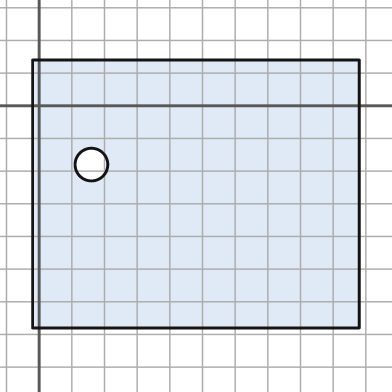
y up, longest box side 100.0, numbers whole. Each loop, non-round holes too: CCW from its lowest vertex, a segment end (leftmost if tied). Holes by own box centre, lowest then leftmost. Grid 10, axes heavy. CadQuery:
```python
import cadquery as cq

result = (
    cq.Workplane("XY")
    .moveTo(-2.0, -68.0)
    .lineTo(98.0, -68.0)
    .lineTo(98.0, 14.0)
    .lineTo(-2.0, 14.0)
    .close()
    .moveTo(16.0, -18.0)
    .circle(5.0)
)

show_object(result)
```